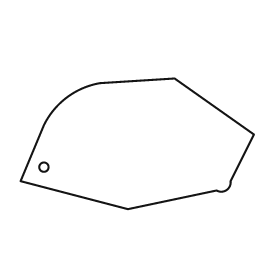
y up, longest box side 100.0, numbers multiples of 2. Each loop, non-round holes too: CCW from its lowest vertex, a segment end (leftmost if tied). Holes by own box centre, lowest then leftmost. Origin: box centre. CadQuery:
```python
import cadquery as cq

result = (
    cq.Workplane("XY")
    .moveTo(-4.0, -28.0)
    .lineTo(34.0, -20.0)
    .threePointArc((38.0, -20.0), (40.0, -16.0))
    .lineTo(50.0, 4.0)
    .lineTo(16.0, 28.0)
    .lineTo(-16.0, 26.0)
    .threePointArc((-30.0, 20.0), (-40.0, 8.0))
    .lineTo(-50.0, -16.0)
    .close()
    .moveTo(-40.0, -10.0)
    .circle(2.0)
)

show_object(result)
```